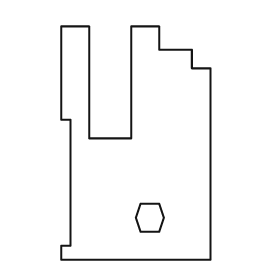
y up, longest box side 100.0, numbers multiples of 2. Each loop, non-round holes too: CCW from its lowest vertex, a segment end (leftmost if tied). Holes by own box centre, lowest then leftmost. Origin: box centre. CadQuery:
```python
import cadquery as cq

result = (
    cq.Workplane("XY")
    .moveTo(-32.0, -50.0)
    .lineTo(32.0, -50.0)
    .lineTo(32.0, 32.0)
    .lineTo(24.0, 32.0)
    .lineTo(24.0, 40.0)
    .lineTo(10.0, 40.0)
    .lineTo(10.0, 50.0)
    .lineTo(-2.0, 50.0)
    .lineTo(-2.0, 2.0)
    .lineTo(-20.0, 2.0)
    .lineTo(-20.0, 50.0)
    .lineTo(-32.0, 50.0)
    .lineTo(-32.0, 10.0)
    .lineTo(-28.0, 10.0)
    .lineTo(-28.0, -44.0)
    .lineTo(-32.0, -44.0)
    .close()
    .moveTo(2.0, -38.0)
    .lineTo(10.0, -38.0)
    .lineTo(12.0, -32.0)
    .lineTo(10.0, -26.0)
    .lineTo(2.0, -26.0)
    .lineTo(0.0, -32.0)
    .close()
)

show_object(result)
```